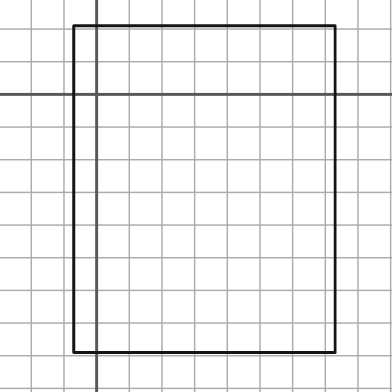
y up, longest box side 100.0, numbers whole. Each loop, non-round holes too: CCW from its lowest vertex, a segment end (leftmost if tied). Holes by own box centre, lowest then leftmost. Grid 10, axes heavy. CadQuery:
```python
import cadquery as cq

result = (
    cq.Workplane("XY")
    .moveTo(-7.0, -79.0)
    .lineTo(73.0, -79.0)
    .lineTo(73.0, 21.0)
    .lineTo(-7.0, 21.0)
    .close()
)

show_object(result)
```